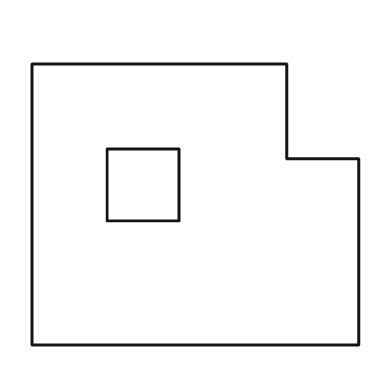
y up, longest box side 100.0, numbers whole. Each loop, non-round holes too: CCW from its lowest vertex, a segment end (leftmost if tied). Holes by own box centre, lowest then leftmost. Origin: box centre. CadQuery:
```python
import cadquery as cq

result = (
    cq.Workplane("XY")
    .moveTo(-50.0, -43.0)
    .lineTo(50.0, -43.0)
    .lineTo(50.0, 14.0)
    .lineTo(28.0, 14.0)
    .lineTo(28.0, 43.0)
    .lineTo(-50.0, 43.0)
    .close()
    .moveTo(-27.0, -5.0)
    .lineTo(-5.0, -5.0)
    .lineTo(-5.0, 17.0)
    .lineTo(-27.0, 17.0)
    .close()
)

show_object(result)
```